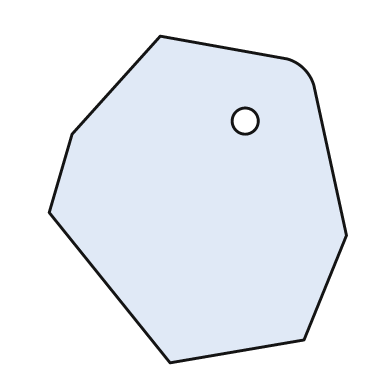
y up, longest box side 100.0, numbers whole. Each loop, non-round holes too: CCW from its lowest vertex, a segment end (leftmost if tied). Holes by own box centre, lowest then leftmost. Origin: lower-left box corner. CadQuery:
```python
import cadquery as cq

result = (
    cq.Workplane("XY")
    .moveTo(37.0, 0.0)
    .lineTo(78.0, 7.0)
    .lineTo(91.0, 39.0)
    .lineTo(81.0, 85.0)
    .threePointArc((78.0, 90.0), (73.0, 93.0))
    .lineTo(34.0, 100.0)
    .lineTo(7.0, 70.0)
    .lineTo(0.0, 46.0)
    .close()
    .moveTo(60.0, 74.0)
    .circle(4.0)
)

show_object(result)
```